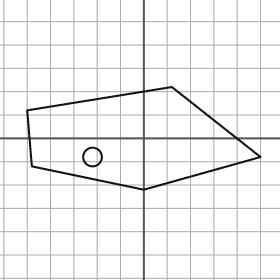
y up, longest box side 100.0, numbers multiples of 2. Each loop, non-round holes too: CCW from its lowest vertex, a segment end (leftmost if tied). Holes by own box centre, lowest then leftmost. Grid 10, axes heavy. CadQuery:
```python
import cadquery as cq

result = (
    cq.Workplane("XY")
    .moveTo(0.0, -22.0)
    .lineTo(50.0, -8.0)
    .lineTo(12.0, 22.0)
    .lineTo(-50.0, 12.0)
    .lineTo(-48.0, -12.0)
    .close()
    .moveTo(-22.0, -8.0)
    .circle(4.0)
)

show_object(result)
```